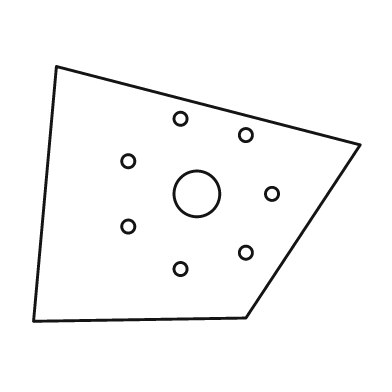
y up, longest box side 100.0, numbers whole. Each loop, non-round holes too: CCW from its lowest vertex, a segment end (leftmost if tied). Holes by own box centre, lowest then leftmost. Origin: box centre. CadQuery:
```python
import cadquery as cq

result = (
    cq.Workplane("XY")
    .moveTo(-50.0, -39.0)
    .lineTo(15.0, -38.0)
    .lineTo(50.0, 15.0)
    .lineTo(-43.0, 39.0)
    .close()
    .moveTo(-5.0, -23.0)
    .circle(2.0)
    .moveTo(15.0, -18.0)
    .circle(2.0)
    .moveTo(-21.0, -10.0)
    .circle(2.0)
    .moveTo(0.0, 0.0)
    .circle(7.0)
    .moveTo(23.0, 0.0)
    .circle(2.0)
    .moveTo(-21.0, 10.0)
    .circle(2.0)
    .moveTo(15.0, 18.0)
    .circle(2.0)
    .moveTo(-5.0, 23.0)
    .circle(2.0)
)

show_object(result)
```